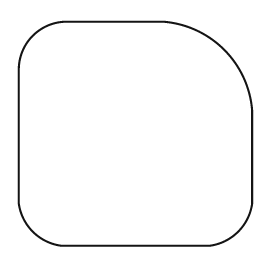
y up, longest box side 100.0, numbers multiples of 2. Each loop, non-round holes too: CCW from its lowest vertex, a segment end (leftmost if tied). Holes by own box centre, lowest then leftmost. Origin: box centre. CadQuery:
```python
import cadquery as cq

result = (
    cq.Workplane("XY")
    .moveTo(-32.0, -48.0)
    .lineTo(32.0, -48.0)
    .threePointArc((44.0, -42.0), (50.0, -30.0))
    .lineTo(50.0, 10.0)
    .threePointArc((38.0, 36.0), (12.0, 48.0))
    .lineTo(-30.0, 48.0)
    .threePointArc((-44.0, 42.0), (-50.0, 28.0))
    .lineTo(-50.0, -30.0)
    .threePointArc((-44.0, -42.0), (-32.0, -48.0))
    .close()
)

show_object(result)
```